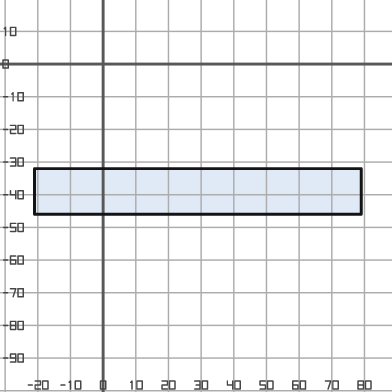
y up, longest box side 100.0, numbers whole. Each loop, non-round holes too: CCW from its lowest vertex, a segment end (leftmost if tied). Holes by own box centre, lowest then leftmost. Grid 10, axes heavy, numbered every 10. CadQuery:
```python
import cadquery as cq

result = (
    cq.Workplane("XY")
    .moveTo(-21.0, -46.0)
    .lineTo(79.0, -46.0)
    .lineTo(79.0, -32.0)
    .lineTo(-21.0, -32.0)
    .close()
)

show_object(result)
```